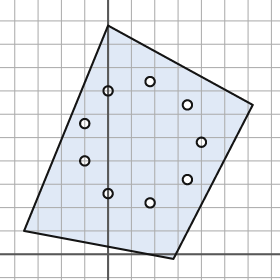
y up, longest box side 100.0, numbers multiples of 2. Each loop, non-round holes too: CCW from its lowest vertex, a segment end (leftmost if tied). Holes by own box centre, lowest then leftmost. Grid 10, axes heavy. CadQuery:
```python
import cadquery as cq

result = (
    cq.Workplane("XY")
    .moveTo(28.0, -2.0)
    .lineTo(62.0, 64.0)
    .lineTo(0.0, 98.0)
    .lineTo(-36.0, 10.0)
    .close()
    .moveTo(18.0, 22.0)
    .circle(2.0)
    .moveTo(0.0, 26.0)
    .circle(2.0)
    .moveTo(34.0, 32.0)
    .circle(2.0)
    .moveTo(-10.0, 40.0)
    .circle(2.0)
    .moveTo(40.0, 48.0)
    .circle(2.0)
    .moveTo(-10.0, 56.0)
    .circle(2.0)
    .moveTo(34.0, 64.0)
    .circle(2.0)
    .moveTo(0.0, 70.0)
    .circle(2.0)
    .moveTo(18.0, 74.0)
    .circle(2.0)
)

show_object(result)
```